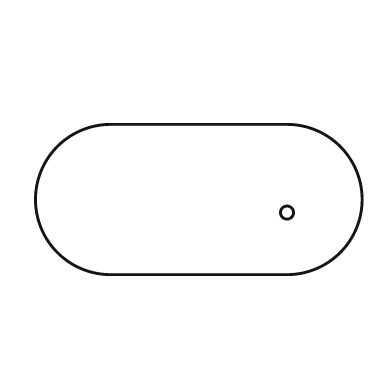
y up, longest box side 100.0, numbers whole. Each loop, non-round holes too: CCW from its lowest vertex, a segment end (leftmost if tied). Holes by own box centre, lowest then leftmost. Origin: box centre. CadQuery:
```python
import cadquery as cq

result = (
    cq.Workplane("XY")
    .moveTo(-27.0, -23.0)
    .lineTo(27.0, -23.0)
    .threePointArc((50.0, 0.0), (27.0, 23.0))
    .lineTo(-27.0, 23.0)
    .threePointArc((-50.0, 0.0), (-27.0, -23.0))
    .close()
    .moveTo(27.0, -4.0)
    .circle(2.0)
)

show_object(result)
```